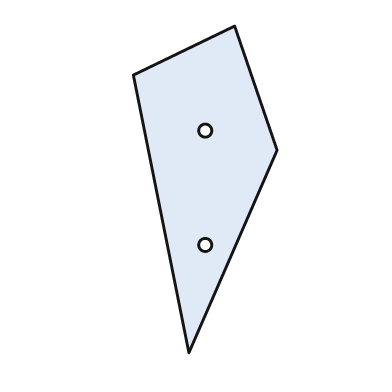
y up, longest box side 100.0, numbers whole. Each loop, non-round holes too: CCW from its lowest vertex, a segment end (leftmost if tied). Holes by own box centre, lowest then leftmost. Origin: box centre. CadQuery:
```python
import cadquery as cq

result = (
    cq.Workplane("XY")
    .moveTo(-5.0, -50.0)
    .lineTo(22.0, 12.0)
    .lineTo(9.0, 50.0)
    .lineTo(-22.0, 35.0)
    .close()
    .moveTo(0.0, -17.0)
    .circle(2.0)
    .moveTo(0.0, 18.0)
    .circle(2.0)
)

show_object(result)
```